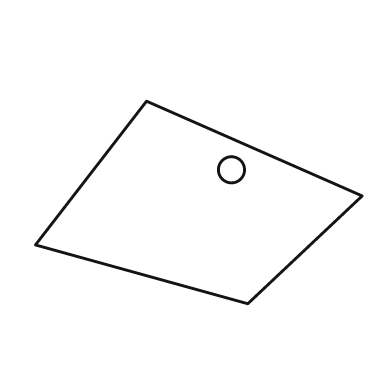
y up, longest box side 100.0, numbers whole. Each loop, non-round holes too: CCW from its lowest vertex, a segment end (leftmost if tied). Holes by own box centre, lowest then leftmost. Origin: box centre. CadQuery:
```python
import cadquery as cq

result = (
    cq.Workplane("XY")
    .moveTo(15.0, -31.0)
    .lineTo(50.0, 2.0)
    .lineTo(-16.0, 31.0)
    .lineTo(-50.0, -13.0)
    .close()
    .moveTo(10.0, 10.0)
    .circle(4.0)
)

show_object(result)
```